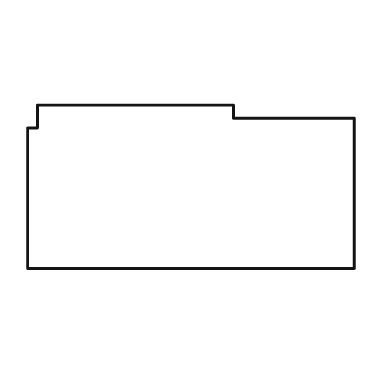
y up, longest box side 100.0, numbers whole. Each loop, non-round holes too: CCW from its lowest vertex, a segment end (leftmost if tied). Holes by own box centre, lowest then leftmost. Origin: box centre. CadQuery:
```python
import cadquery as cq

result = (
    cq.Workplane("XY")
    .moveTo(-50.0, -25.0)
    .lineTo(50.0, -25.0)
    .lineTo(50.0, 21.0)
    .lineTo(13.0, 21.0)
    .lineTo(13.0, 25.0)
    .lineTo(-47.0, 25.0)
    .lineTo(-47.0, 18.0)
    .lineTo(-50.0, 18.0)
    .close()
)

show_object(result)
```